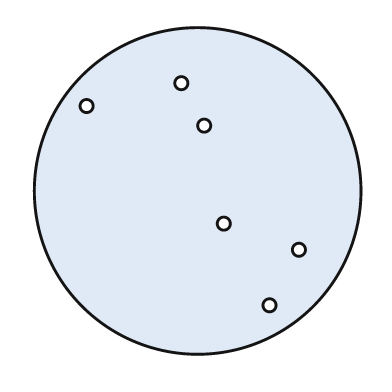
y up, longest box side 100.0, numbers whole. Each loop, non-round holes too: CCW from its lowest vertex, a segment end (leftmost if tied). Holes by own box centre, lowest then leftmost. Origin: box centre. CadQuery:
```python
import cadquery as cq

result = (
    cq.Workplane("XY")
    .moveTo(0.0, 0.0)
    .circle(50.0)
    .moveTo(22.0, -35.0)
    .circle(2.0)
    .moveTo(31.0, -18.0)
    .circle(2.0)
    .moveTo(8.0, -10.0)
    .circle(2.0)
    .moveTo(2.0, 20.0)
    .circle(2.0)
    .moveTo(-34.0, 26.0)
    .circle(2.0)
    .moveTo(-5.0, 33.0)
    .circle(2.0)
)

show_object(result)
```